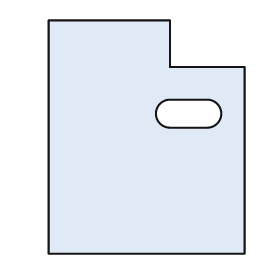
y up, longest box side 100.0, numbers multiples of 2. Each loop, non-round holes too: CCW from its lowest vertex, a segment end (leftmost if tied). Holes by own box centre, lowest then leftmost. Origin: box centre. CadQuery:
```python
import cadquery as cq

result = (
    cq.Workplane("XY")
    .moveTo(-42.0, -50.0)
    .lineTo(42.0, -50.0)
    .lineTo(42.0, 30.0)
    .lineTo(10.0, 30.0)
    .lineTo(10.0, 50.0)
    .lineTo(-42.0, 50.0)
    .close()
    .moveTo(10.0, 4.0)
    .lineTo(26.0, 4.0)
    .threePointArc((32.0, 10.0), (26.0, 16.0))
    .lineTo(10.0, 16.0)
    .threePointArc((4.0, 10.0), (10.0, 4.0))
    .close()
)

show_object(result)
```